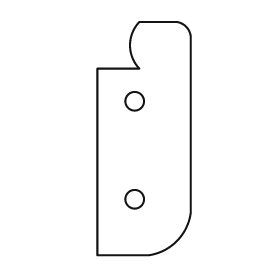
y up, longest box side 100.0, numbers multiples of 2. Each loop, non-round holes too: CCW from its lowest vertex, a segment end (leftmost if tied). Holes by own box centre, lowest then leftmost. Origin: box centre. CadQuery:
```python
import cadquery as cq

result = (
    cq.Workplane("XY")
    .moveTo(-20.0, -50.0)
    .lineTo(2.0, -50.0)
    .threePointArc((14.0, -44.0), (20.0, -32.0))
    .lineTo(20.0, 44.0)
    .threePointArc((18.0, 48.0), (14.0, 50.0))
    .lineTo(-2.0, 50.0)
    .threePointArc((-6.0, 40.0), (-2.0, 30.0))
    .lineTo(-20.0, 30.0)
    .close()
    .moveTo(-4.0, -26.0)
    .circle(4.0)
    .moveTo(-4.0, 16.0)
    .circle(4.0)
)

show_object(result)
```